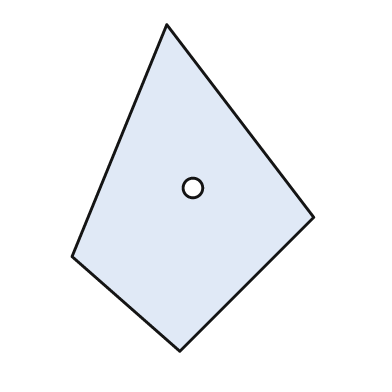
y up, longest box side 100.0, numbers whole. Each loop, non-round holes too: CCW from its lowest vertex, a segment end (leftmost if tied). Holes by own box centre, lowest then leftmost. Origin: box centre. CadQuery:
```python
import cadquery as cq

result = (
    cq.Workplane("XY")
    .moveTo(-4.0, -50.0)
    .lineTo(37.0, -9.0)
    .lineTo(-8.0, 50.0)
    .lineTo(-37.0, -21.0)
    .close()
    .moveTo(0.0, 0.0)
    .circle(3.0)
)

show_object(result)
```